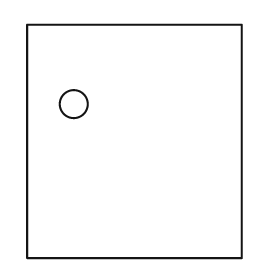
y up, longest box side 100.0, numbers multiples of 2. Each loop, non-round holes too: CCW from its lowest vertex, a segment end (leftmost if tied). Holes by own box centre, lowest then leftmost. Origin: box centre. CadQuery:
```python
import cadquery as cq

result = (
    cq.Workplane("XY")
    .moveTo(-46.0, -50.0)
    .lineTo(46.0, -50.0)
    .lineTo(46.0, 50.0)
    .lineTo(-46.0, 50.0)
    .close()
    .moveTo(-26.0, 16.0)
    .circle(6.0)
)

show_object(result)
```